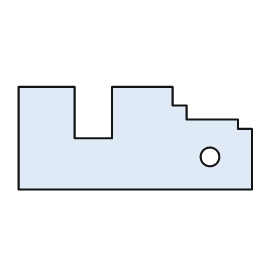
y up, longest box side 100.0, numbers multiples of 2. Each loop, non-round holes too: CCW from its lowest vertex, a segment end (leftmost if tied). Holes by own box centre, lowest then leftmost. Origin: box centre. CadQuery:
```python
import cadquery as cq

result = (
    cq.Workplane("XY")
    .moveTo(-50.0, -22.0)
    .lineTo(50.0, -22.0)
    .lineTo(50.0, 4.0)
    .lineTo(44.0, 4.0)
    .lineTo(44.0, 8.0)
    .lineTo(22.0, 8.0)
    .lineTo(22.0, 14.0)
    .lineTo(16.0, 14.0)
    .lineTo(16.0, 22.0)
    .lineTo(-10.0, 22.0)
    .lineTo(-10.0, 0.0)
    .lineTo(-26.0, 0.0)
    .lineTo(-26.0, 22.0)
    .lineTo(-50.0, 22.0)
    .close()
    .moveTo(32.0, -8.0)
    .circle(4.0)
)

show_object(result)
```